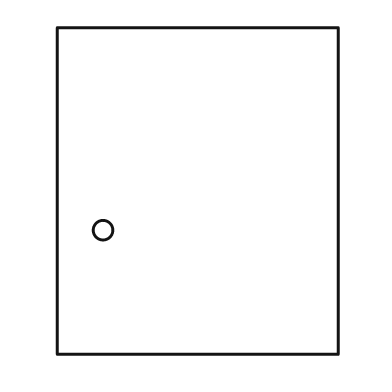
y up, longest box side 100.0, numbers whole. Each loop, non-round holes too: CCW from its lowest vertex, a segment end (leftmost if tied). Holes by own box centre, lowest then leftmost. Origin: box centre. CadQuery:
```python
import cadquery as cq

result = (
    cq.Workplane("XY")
    .moveTo(-43.0, -50.0)
    .lineTo(43.0, -50.0)
    .lineTo(43.0, 50.0)
    .lineTo(-43.0, 50.0)
    .close()
    .moveTo(-29.0, -12.0)
    .circle(3.0)
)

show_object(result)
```